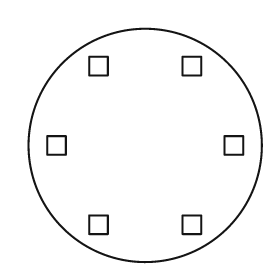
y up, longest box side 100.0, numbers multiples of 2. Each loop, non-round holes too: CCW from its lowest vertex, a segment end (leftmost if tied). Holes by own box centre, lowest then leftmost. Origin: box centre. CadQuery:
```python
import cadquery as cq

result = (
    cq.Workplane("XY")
    .moveTo(0.0, 0.0)
    .circle(50.0)
    .moveTo(-24.0, -38.0)
    .lineTo(-16.0, -38.0)
    .lineTo(-16.0, -30.0)
    .lineTo(-24.0, -30.0)
    .close()
    .moveTo(16.0, -38.0)
    .lineTo(24.0, -38.0)
    .lineTo(24.0, -30.0)
    .lineTo(16.0, -30.0)
    .close()
    .moveTo(-42.0, -4.0)
    .lineTo(-34.0, -4.0)
    .lineTo(-34.0, 4.0)
    .lineTo(-42.0, 4.0)
    .close()
    .moveTo(34.0, -4.0)
    .lineTo(42.0, -4.0)
    .lineTo(42.0, 4.0)
    .lineTo(34.0, 4.0)
    .close()
    .moveTo(-24.0, 30.0)
    .lineTo(-16.0, 30.0)
    .lineTo(-16.0, 38.0)
    .lineTo(-24.0, 38.0)
    .close()
    .moveTo(16.0, 30.0)
    .lineTo(24.0, 30.0)
    .lineTo(24.0, 38.0)
    .lineTo(16.0, 38.0)
    .close()
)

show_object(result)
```